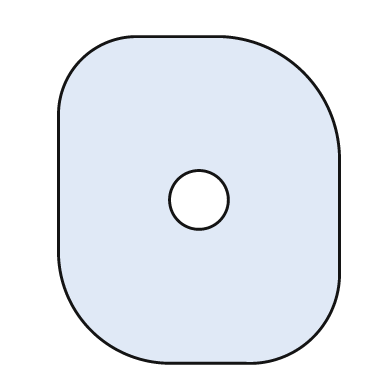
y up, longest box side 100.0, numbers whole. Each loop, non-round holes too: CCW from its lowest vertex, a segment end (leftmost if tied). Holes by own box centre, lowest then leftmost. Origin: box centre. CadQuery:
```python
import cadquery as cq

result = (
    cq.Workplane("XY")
    .moveTo(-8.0, -50.0)
    .lineTo(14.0, -50.0)
    .threePointArc((35.0, -42.0), (43.0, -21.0))
    .lineTo(43.0, 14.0)
    .threePointArc((32.0, 39.0), (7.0, 50.0))
    .lineTo(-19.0, 50.0)
    .threePointArc((-36.0, 43.0), (-43.0, 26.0))
    .lineTo(-43.0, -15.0)
    .threePointArc((-33.0, -40.0), (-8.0, -50.0))
    .close()
    .moveTo(0.0, 0.0)
    .circle(9.0)
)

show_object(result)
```